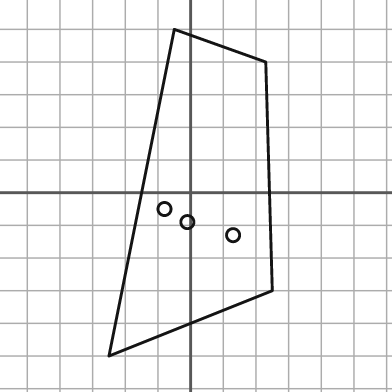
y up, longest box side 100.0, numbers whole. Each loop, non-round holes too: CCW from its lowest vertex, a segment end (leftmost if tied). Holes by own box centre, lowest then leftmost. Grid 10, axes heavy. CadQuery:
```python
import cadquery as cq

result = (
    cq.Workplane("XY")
    .moveTo(-25.0, -50.0)
    .lineTo(25.0, -30.0)
    .lineTo(23.0, 40.0)
    .lineTo(-5.0, 50.0)
    .close()
    .moveTo(13.0, -13.0)
    .circle(2.0)
    .moveTo(-1.0, -9.0)
    .circle(2.0)
    .moveTo(-8.0, -5.0)
    .circle(2.0)
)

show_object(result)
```